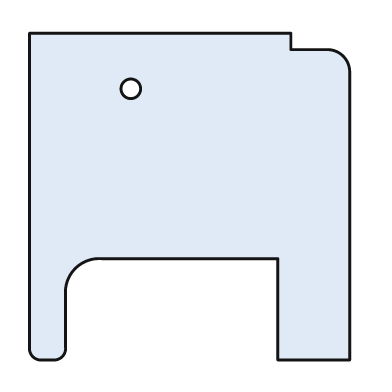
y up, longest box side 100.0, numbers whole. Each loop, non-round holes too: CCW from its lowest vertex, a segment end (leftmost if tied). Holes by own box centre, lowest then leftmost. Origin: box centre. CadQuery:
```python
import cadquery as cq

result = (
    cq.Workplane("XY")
    .moveTo(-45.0, -50.0)
    .lineTo(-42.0, -50.0)
    .threePointArc((-39.0, -49.0), (-38.0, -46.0))
    .lineTo(-38.0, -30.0)
    .threePointArc((-35.0, -22.0), (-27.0, -19.0))
    .lineTo(27.0, -19.0)
    .lineTo(27.0, -50.0)
    .lineTo(49.0, -50.0)
    .lineTo(49.0, 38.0)
    .threePointArc((47.0, 43.0), (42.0, 45.0))
    .lineTo(31.0, 45.0)
    .lineTo(31.0, 50.0)
    .lineTo(-49.0, 50.0)
    .lineTo(-49.0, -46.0)
    .threePointArc((-48.0, -49.0), (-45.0, -50.0))
    .close()
    .moveTo(-18.0, 33.0)
    .circle(3.0)
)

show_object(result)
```